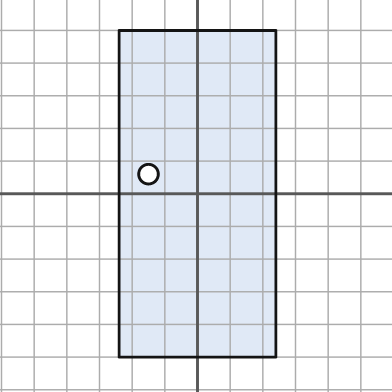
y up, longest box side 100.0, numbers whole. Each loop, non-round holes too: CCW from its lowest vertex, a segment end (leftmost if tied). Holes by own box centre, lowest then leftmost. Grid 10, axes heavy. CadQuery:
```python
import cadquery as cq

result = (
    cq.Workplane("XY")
    .moveTo(-24.0, -50.0)
    .lineTo(24.0, -50.0)
    .lineTo(24.0, 50.0)
    .lineTo(-24.0, 50.0)
    .close()
    .moveTo(-15.0, 6.0)
    .circle(3.0)
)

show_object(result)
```